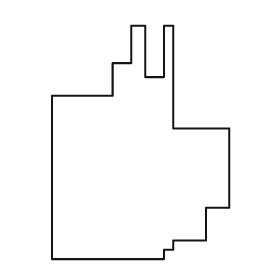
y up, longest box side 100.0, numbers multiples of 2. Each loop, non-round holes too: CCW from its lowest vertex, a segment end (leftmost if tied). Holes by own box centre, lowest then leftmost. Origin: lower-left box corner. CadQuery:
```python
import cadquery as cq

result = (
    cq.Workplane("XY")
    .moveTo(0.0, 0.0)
    .lineTo(48.0, 0.0)
    .lineTo(48.0, 4.0)
    .lineTo(52.0, 4.0)
    .lineTo(52.0, 8.0)
    .lineTo(66.0, 8.0)
    .lineTo(66.0, 22.0)
    .lineTo(76.0, 22.0)
    .lineTo(76.0, 56.0)
    .lineTo(52.0, 56.0)
    .lineTo(52.0, 100.0)
    .lineTo(48.0, 100.0)
    .lineTo(48.0, 78.0)
    .lineTo(40.0, 78.0)
    .lineTo(40.0, 100.0)
    .lineTo(34.0, 100.0)
    .lineTo(34.0, 84.0)
    .lineTo(26.0, 84.0)
    .lineTo(26.0, 70.0)
    .lineTo(0.0, 70.0)
    .close()
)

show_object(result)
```